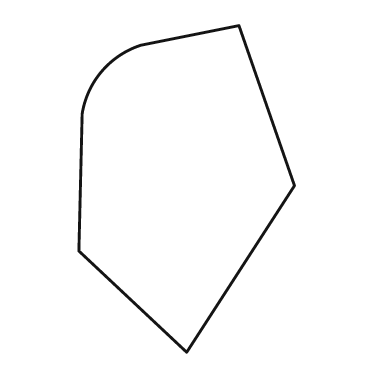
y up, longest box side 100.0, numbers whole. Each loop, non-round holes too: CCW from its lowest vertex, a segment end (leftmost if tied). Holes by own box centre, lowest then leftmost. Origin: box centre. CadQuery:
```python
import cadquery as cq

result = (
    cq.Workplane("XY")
    .moveTo(0.0, -50.0)
    .lineTo(33.0, 1.0)
    .lineTo(16.0, 50.0)
    .lineTo(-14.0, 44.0)
    .threePointArc((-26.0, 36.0), (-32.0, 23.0))
    .lineTo(-33.0, -19.0)
    .close()
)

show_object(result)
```